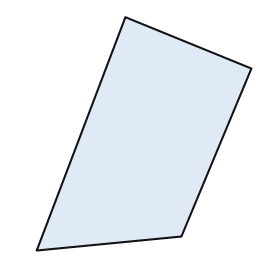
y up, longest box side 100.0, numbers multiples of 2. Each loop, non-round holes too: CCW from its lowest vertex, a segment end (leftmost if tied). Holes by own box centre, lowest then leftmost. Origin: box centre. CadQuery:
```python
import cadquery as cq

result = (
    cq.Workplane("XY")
    .moveTo(-46.0, -50.0)
    .lineTo(16.0, -44.0)
    .lineTo(46.0, 28.0)
    .lineTo(-8.0, 50.0)
    .close()
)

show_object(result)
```